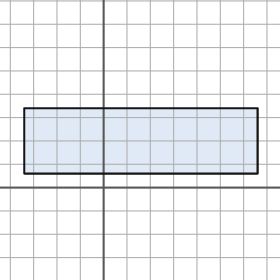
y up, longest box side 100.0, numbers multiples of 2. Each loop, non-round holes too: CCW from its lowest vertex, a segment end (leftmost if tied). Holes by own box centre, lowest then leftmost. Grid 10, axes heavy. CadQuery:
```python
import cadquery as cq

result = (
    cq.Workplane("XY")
    .moveTo(-34.0, 6.0)
    .lineTo(66.0, 6.0)
    .lineTo(66.0, 34.0)
    .lineTo(-34.0, 34.0)
    .close()
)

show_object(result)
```